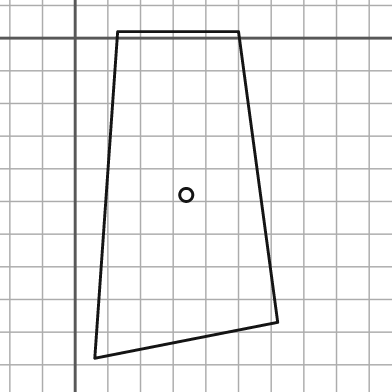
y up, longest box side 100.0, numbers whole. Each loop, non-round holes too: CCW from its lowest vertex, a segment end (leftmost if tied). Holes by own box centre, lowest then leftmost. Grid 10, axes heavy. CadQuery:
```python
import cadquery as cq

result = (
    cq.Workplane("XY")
    .moveTo(6.0, -98.0)
    .lineTo(62.0, -87.0)
    .lineTo(50.0, 2.0)
    .lineTo(13.0, 2.0)
    .close()
    .moveTo(34.0, -48.0)
    .circle(2.0)
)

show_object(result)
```